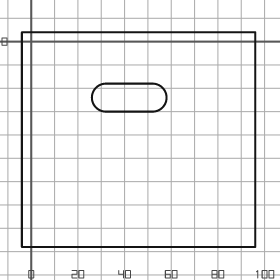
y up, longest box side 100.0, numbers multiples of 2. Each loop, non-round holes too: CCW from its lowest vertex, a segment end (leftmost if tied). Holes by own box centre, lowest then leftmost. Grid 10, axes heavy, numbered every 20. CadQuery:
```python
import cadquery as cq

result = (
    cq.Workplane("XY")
    .moveTo(-4.0, -88.0)
    .lineTo(96.0, -88.0)
    .lineTo(96.0, 4.0)
    .lineTo(-4.0, 4.0)
    .close()
    .moveTo(32.0, -30.0)
    .lineTo(52.0, -30.0)
    .threePointArc((58.0, -24.0), (52.0, -18.0))
    .lineTo(32.0, -18.0)
    .threePointArc((26.0, -24.0), (32.0, -30.0))
    .close()
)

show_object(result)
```